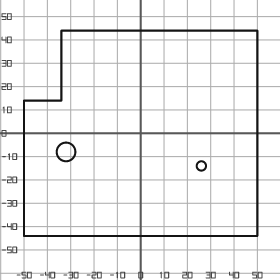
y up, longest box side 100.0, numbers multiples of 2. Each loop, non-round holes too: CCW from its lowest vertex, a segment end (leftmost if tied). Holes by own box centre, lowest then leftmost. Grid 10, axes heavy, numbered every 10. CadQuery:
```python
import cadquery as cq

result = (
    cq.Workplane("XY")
    .moveTo(-50.0, -44.0)
    .lineTo(50.0, -44.0)
    .lineTo(50.0, 44.0)
    .lineTo(-34.0, 44.0)
    .lineTo(-34.0, 14.0)
    .lineTo(-50.0, 14.0)
    .close()
    .moveTo(26.0, -14.0)
    .circle(2.0)
    .moveTo(-32.0, -8.0)
    .circle(4.0)
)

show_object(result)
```